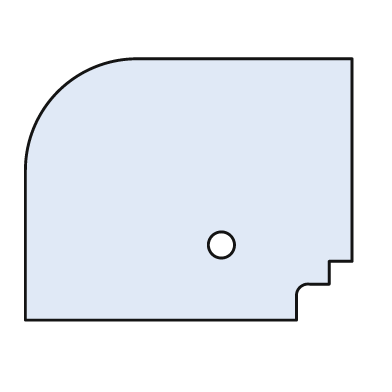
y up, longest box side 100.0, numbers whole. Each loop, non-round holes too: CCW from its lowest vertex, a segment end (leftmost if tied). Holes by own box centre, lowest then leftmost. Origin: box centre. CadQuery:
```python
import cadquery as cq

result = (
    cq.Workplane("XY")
    .moveTo(-50.0, -40.0)
    .lineTo(33.0, -40.0)
    .lineTo(33.0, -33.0)
    .threePointArc((34.0, -30.0), (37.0, -29.0))
    .lineTo(43.0, -29.0)
    .lineTo(43.0, -22.0)
    .lineTo(50.0, -22.0)
    .lineTo(50.0, 40.0)
    .lineTo(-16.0, 40.0)
    .threePointArc((-40.0, 30.0), (-50.0, 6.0))
    .close()
    .moveTo(10.0, -17.0)
    .circle(4.0)
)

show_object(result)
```